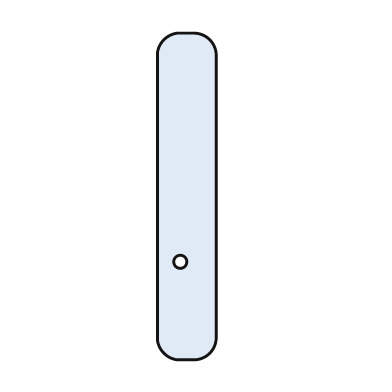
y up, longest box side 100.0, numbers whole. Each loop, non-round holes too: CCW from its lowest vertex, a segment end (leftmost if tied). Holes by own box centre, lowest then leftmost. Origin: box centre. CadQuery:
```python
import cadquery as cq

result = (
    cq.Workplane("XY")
    .moveTo(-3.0, -50.0)
    .lineTo(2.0, -50.0)
    .threePointArc((7.0, -48.0), (9.0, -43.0))
    .lineTo(9.0, 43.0)
    .threePointArc((7.0, 48.0), (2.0, 50.0))
    .lineTo(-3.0, 50.0)
    .threePointArc((-7.0, 48.0), (-9.0, 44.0))
    .lineTo(-9.0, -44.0)
    .threePointArc((-7.0, -48.0), (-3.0, -50.0))
    .close()
    .moveTo(-2.0, -20.0)
    .circle(2.0)
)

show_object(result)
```